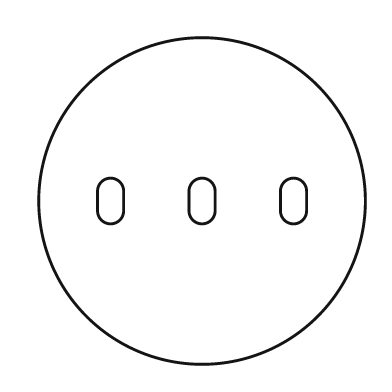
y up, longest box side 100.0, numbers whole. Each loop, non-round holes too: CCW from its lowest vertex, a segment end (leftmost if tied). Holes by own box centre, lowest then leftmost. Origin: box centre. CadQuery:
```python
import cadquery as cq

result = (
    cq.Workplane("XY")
    .moveTo(0.0, 0.0)
    .circle(50.0)
    .moveTo(-32.0, -3.0)
    .threePointArc((-28.0, -7.0), (-24.0, -3.0))
    .lineTo(-24.0, 3.0)
    .threePointArc((-28.0, 7.0), (-32.0, 3.0))
    .close()
    .moveTo(-4.0, -3.0)
    .threePointArc((0.0, -7.0), (4.0, -3.0))
    .lineTo(4.0, 3.0)
    .threePointArc((0.0, 7.0), (-4.0, 3.0))
    .close()
    .moveTo(24.0, -3.0)
    .threePointArc((28.0, -7.0), (32.0, -3.0))
    .lineTo(32.0, 3.0)
    .threePointArc((28.0, 7.0), (24.0, 3.0))
    .close()
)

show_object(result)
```